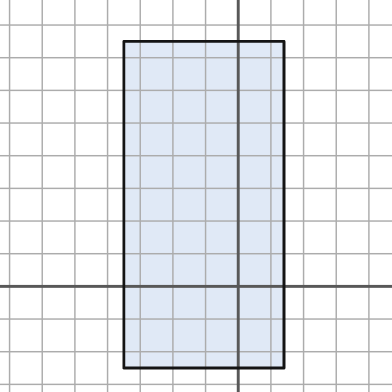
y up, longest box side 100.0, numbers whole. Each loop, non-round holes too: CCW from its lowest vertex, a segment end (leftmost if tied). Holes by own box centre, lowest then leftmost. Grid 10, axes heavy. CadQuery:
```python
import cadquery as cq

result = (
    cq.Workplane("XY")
    .moveTo(-35.0, -25.0)
    .lineTo(14.0, -25.0)
    .lineTo(14.0, 75.0)
    .lineTo(-35.0, 75.0)
    .close()
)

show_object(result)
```